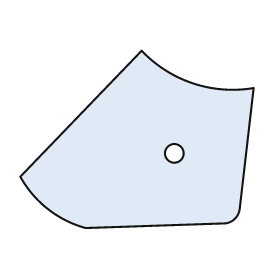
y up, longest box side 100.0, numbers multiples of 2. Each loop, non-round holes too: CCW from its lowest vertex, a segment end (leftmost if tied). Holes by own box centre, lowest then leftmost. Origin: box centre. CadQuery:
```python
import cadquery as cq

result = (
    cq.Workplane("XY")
    .moveTo(-22.0, -38.0)
    .lineTo(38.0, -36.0)
    .threePointArc((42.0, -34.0), (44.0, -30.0))
    .lineTo(50.0, 22.0)
    .threePointArc((24.0, 24.0), (2.0, 38.0))
    .lineTo(-50.0, -16.0)
    .threePointArc((-38.0, -30.0), (-22.0, -38.0))
    .close()
    .moveTo(16.0, -6.0)
    .circle(4.0)
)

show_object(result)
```